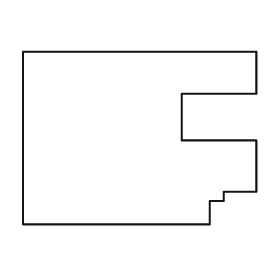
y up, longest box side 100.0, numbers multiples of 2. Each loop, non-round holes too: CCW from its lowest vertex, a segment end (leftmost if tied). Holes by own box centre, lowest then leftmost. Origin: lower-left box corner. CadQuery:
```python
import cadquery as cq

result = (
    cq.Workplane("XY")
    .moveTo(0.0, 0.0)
    .lineTo(80.0, 0.0)
    .lineTo(80.0, 10.0)
    .lineTo(86.0, 10.0)
    .lineTo(86.0, 14.0)
    .lineTo(100.0, 14.0)
    .lineTo(100.0, 36.0)
    .lineTo(68.0, 36.0)
    .lineTo(68.0, 56.0)
    .lineTo(100.0, 56.0)
    .lineTo(100.0, 74.0)
    .lineTo(0.0, 74.0)
    .close()
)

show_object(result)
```